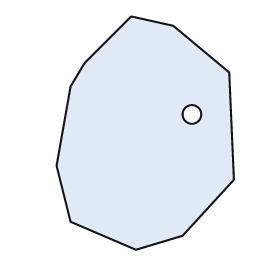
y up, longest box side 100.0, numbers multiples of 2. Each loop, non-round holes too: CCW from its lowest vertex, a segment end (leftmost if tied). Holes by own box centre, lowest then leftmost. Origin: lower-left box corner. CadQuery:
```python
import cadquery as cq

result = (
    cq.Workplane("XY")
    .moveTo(34.0, 0.0)
    .lineTo(54.0, 6.0)
    .lineTo(76.0, 30.0)
    .lineTo(74.0, 76.0)
    .lineTo(50.0, 96.0)
    .lineTo(32.0, 100.0)
    .lineTo(12.0, 80.0)
    .lineTo(6.0, 70.0)
    .lineTo(0.0, 36.0)
    .lineTo(6.0, 12.0)
    .close()
    .moveTo(58.0, 58.0)
    .circle(4.0)
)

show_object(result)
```